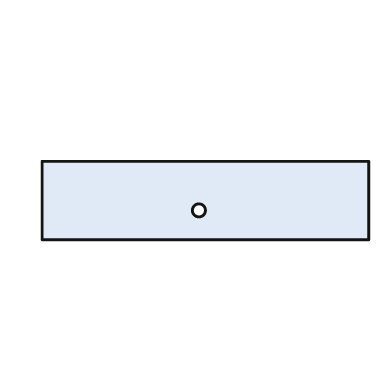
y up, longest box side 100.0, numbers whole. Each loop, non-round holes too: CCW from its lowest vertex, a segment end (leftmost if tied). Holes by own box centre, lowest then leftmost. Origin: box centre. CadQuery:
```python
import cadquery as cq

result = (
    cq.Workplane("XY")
    .moveTo(-50.0, -12.0)
    .lineTo(50.0, -12.0)
    .lineTo(50.0, 12.0)
    .lineTo(-50.0, 12.0)
    .close()
    .moveTo(-2.0, -3.0)
    .circle(2.0)
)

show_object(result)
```